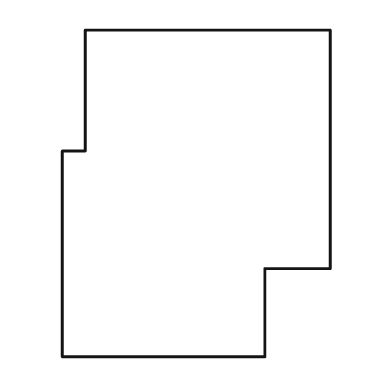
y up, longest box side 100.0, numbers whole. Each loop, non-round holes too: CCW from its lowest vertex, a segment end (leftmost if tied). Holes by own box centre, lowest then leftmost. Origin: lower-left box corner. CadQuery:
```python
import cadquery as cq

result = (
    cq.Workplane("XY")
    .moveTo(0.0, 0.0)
    .lineTo(62.0, 0.0)
    .lineTo(62.0, 27.0)
    .lineTo(82.0, 27.0)
    .lineTo(82.0, 100.0)
    .lineTo(7.0, 100.0)
    .lineTo(7.0, 63.0)
    .lineTo(0.0, 63.0)
    .close()
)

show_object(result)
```